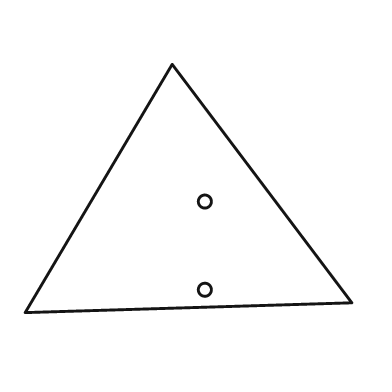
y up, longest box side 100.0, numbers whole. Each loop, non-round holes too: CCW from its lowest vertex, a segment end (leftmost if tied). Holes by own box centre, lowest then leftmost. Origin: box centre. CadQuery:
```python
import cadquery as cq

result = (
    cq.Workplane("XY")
    .moveTo(-50.0, -38.0)
    .lineTo(50.0, -35.0)
    .lineTo(-5.0, 38.0)
    .close()
    .moveTo(5.0, -31.0)
    .circle(2.0)
    .moveTo(5.0, -4.0)
    .circle(2.0)
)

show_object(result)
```